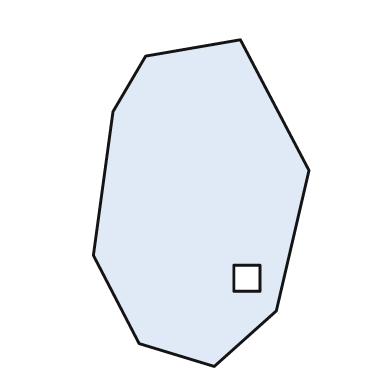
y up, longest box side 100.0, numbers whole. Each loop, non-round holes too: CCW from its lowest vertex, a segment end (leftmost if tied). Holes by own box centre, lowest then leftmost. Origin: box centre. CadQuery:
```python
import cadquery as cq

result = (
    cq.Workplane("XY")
    .moveTo(4.0, -50.0)
    .lineTo(23.0, -33.0)
    .lineTo(33.0, 10.0)
    .lineTo(12.0, 50.0)
    .lineTo(-17.0, 45.0)
    .lineTo(-27.0, 28.0)
    .lineTo(-33.0, -16.0)
    .lineTo(-19.0, -43.0)
    .close()
    .moveTo(10.0, -27.0)
    .lineTo(18.0, -27.0)
    .lineTo(18.0, -19.0)
    .lineTo(10.0, -19.0)
    .close()
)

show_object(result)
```